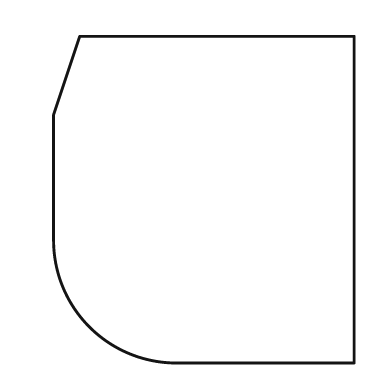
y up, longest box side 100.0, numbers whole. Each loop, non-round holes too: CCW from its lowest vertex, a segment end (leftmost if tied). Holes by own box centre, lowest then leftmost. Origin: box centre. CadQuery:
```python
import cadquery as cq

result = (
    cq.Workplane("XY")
    .moveTo(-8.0, -50.0)
    .lineTo(46.0, -50.0)
    .lineTo(46.0, 50.0)
    .lineTo(-38.0, 50.0)
    .lineTo(-46.0, 26.0)
    .lineTo(-46.0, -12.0)
    .threePointArc((-35.0, -39.0), (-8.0, -50.0))
    .close()
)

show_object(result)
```